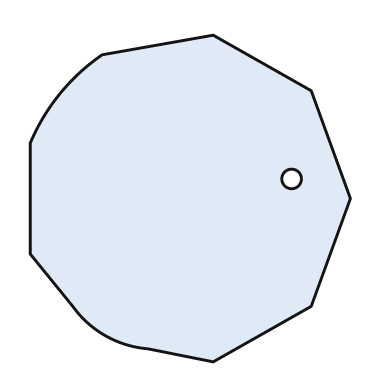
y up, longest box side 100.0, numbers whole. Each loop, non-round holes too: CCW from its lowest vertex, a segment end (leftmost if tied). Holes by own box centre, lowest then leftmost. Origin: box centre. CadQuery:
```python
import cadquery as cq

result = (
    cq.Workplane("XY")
    .moveTo(7.0, -50.0)
    .lineTo(37.0, -33.0)
    .lineTo(49.0, 0.0)
    .lineTo(37.0, 33.0)
    .lineTo(7.0, 50.0)
    .lineTo(-27.0, 44.0)
    .threePointArc((-40.0, 32.0), (-49.0, 17.0))
    .lineTo(-49.0, -17.0)
    .lineTo(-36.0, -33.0)
    .threePointArc((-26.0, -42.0), (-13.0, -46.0))
    .close()
    .moveTo(31.0, 6.0)
    .circle(3.0)
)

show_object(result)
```